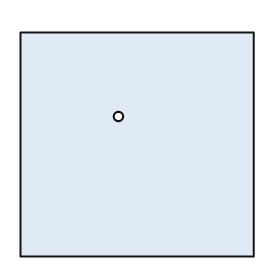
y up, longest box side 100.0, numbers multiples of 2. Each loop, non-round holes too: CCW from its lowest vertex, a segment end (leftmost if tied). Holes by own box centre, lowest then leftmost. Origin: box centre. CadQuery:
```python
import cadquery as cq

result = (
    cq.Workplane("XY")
    .moveTo(-50.0, -48.0)
    .lineTo(50.0, -48.0)
    .lineTo(50.0, 48.0)
    .lineTo(-50.0, 48.0)
    .close()
    .moveTo(-8.0, 12.0)
    .circle(2.0)
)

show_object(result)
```